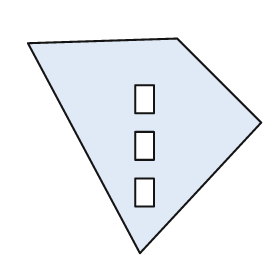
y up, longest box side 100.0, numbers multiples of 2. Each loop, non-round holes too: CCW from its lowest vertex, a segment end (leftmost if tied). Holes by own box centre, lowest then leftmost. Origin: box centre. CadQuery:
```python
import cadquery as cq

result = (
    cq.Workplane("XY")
    .moveTo(-2.0, -46.0)
    .lineTo(50.0, 10.0)
    .lineTo(14.0, 46.0)
    .lineTo(-50.0, 44.0)
    .close()
    .moveTo(-4.0, -26.0)
    .lineTo(4.0, -26.0)
    .lineTo(4.0, -14.0)
    .lineTo(-4.0, -14.0)
    .close()
    .moveTo(-4.0, -6.0)
    .lineTo(4.0, -6.0)
    .lineTo(4.0, 6.0)
    .lineTo(-4.0, 6.0)
    .close()
    .moveTo(-4.0, 14.0)
    .lineTo(4.0, 14.0)
    .lineTo(4.0, 26.0)
    .lineTo(-4.0, 26.0)
    .close()
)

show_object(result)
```